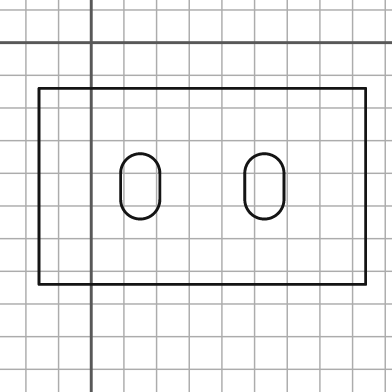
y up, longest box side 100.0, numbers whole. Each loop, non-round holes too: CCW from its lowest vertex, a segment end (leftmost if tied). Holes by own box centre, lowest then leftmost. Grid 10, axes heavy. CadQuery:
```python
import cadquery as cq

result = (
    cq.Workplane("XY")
    .moveTo(-16.0, -74.0)
    .lineTo(84.0, -74.0)
    .lineTo(84.0, -14.0)
    .lineTo(-16.0, -14.0)
    .close()
    .moveTo(9.0, -48.0)
    .threePointArc((15.0, -54.0), (21.0, -48.0))
    .lineTo(21.0, -40.0)
    .threePointArc((15.0, -34.0), (9.0, -40.0))
    .close()
    .moveTo(47.0, -48.0)
    .threePointArc((53.0, -54.0), (59.0, -48.0))
    .lineTo(59.0, -40.0)
    .threePointArc((53.0, -34.0), (47.0, -40.0))
    .close()
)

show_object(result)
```